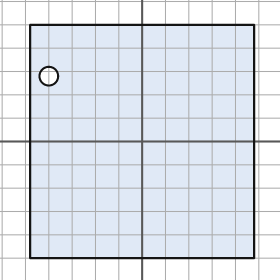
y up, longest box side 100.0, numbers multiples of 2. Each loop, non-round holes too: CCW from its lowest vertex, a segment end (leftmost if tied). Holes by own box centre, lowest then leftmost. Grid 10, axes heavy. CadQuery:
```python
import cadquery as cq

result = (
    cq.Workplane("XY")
    .moveTo(-48.0, -50.0)
    .lineTo(48.0, -50.0)
    .lineTo(48.0, 50.0)
    .lineTo(-48.0, 50.0)
    .close()
    .moveTo(-40.0, 28.0)
    .circle(4.0)
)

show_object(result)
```